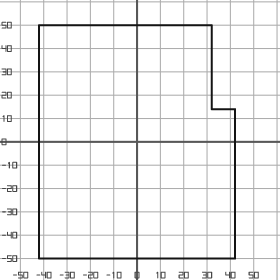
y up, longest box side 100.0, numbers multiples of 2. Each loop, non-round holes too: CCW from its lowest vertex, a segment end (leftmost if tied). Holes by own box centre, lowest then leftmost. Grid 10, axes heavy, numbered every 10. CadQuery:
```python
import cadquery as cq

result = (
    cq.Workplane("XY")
    .moveTo(-42.0, -50.0)
    .lineTo(42.0, -50.0)
    .lineTo(42.0, 14.0)
    .lineTo(32.0, 14.0)
    .lineTo(32.0, 50.0)
    .lineTo(-42.0, 50.0)
    .close()
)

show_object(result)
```